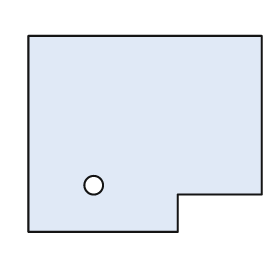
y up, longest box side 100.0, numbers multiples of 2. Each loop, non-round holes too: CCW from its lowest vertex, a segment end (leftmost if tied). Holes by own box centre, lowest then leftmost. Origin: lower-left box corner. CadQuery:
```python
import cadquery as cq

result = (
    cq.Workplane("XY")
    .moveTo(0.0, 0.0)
    .lineTo(64.0, 0.0)
    .lineTo(64.0, 16.0)
    .lineTo(100.0, 16.0)
    .lineTo(100.0, 84.0)
    .lineTo(0.0, 84.0)
    .close()
    .moveTo(28.0, 20.0)
    .circle(4.0)
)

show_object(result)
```